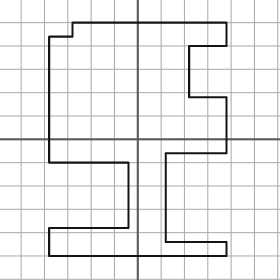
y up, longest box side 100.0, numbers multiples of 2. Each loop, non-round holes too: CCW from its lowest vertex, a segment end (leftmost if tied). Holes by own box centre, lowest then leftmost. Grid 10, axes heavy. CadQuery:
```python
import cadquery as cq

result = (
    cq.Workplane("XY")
    .moveTo(-38.0, -50.0)
    .lineTo(38.0, -50.0)
    .lineTo(38.0, -44.0)
    .lineTo(12.0, -44.0)
    .lineTo(12.0, -6.0)
    .lineTo(38.0, -6.0)
    .lineTo(38.0, 18.0)
    .lineTo(22.0, 18.0)
    .lineTo(22.0, 40.0)
    .lineTo(38.0, 40.0)
    .lineTo(38.0, 50.0)
    .lineTo(-28.0, 50.0)
    .lineTo(-28.0, 44.0)
    .lineTo(-38.0, 44.0)
    .lineTo(-38.0, -10.0)
    .lineTo(-4.0, -10.0)
    .lineTo(-4.0, -38.0)
    .lineTo(-38.0, -38.0)
    .close()
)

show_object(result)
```